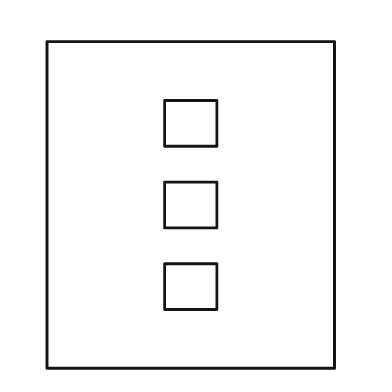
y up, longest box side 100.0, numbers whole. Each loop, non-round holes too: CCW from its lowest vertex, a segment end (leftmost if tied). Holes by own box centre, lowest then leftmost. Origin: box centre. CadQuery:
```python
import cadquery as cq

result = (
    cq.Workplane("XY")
    .moveTo(-44.0, -50.0)
    .lineTo(44.0, -50.0)
    .lineTo(44.0, 50.0)
    .lineTo(-44.0, 50.0)
    .close()
    .moveTo(-8.0, -32.0)
    .lineTo(8.0, -32.0)
    .lineTo(8.0, -18.0)
    .lineTo(-8.0, -18.0)
    .close()
    .moveTo(-8.0, -7.0)
    .lineTo(8.0, -7.0)
    .lineTo(8.0, 7.0)
    .lineTo(-8.0, 7.0)
    .close()
    .moveTo(-8.0, 18.0)
    .lineTo(8.0, 18.0)
    .lineTo(8.0, 32.0)
    .lineTo(-8.0, 32.0)
    .close()
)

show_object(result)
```